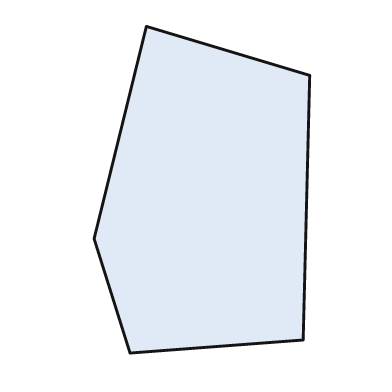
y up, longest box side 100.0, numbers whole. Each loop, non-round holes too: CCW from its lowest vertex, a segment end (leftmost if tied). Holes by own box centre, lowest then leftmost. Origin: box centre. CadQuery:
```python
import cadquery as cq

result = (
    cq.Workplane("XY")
    .moveTo(-22.0, -50.0)
    .lineTo(31.0, -46.0)
    .lineTo(33.0, 35.0)
    .lineTo(-17.0, 50.0)
    .lineTo(-33.0, -15.0)
    .close()
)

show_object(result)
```